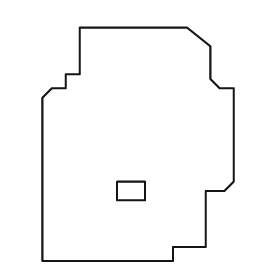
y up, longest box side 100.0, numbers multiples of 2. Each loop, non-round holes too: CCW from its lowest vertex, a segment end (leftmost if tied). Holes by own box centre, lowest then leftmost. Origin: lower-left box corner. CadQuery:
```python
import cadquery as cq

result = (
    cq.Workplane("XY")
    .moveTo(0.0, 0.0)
    .lineTo(56.0, 0.0)
    .lineTo(56.0, 6.0)
    .lineTo(70.0, 6.0)
    .lineTo(70.0, 30.0)
    .lineTo(78.0, 30.0)
    .lineTo(82.0, 34.0)
    .lineTo(82.0, 74.0)
    .lineTo(76.0, 74.0)
    .lineTo(72.0, 78.0)
    .lineTo(72.0, 92.0)
    .lineTo(62.0, 100.0)
    .lineTo(16.0, 100.0)
    .lineTo(16.0, 80.0)
    .lineTo(10.0, 80.0)
    .lineTo(10.0, 74.0)
    .lineTo(4.0, 74.0)
    .lineTo(0.0, 70.0)
    .close()
    .moveTo(32.0, 26.0)
    .lineTo(44.0, 26.0)
    .lineTo(44.0, 34.0)
    .lineTo(32.0, 34.0)
    .close()
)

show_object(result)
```